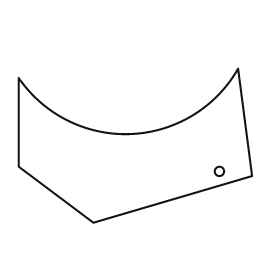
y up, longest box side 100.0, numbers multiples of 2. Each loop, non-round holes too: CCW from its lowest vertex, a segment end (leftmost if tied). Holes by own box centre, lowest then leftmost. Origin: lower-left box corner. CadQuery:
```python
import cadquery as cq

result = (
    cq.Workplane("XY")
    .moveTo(32.0, 0.0)
    .lineTo(100.0, 20.0)
    .lineTo(94.0, 66.0)
    .threePointArc((48.0, 38.0), (0.0, 62.0))
    .lineTo(0.0, 24.0)
    .close()
    .moveTo(86.0, 22.0)
    .circle(2.0)
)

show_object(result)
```